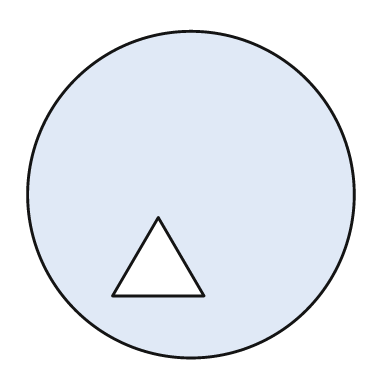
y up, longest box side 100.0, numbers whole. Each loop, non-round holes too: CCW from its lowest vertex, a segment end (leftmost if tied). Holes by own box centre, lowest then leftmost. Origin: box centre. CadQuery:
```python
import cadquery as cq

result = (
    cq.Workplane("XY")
    .moveTo(0.0, 0.0)
    .circle(50.0)
    .moveTo(-24.0, -31.0)
    .lineTo(4.0, -31.0)
    .lineTo(-10.0, -7.0)
    .close()
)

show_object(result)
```